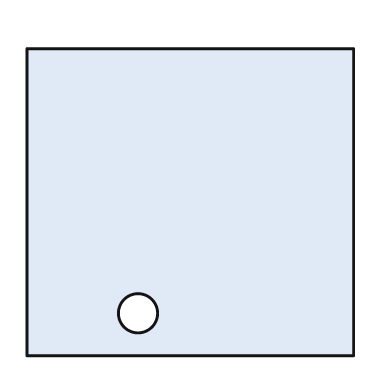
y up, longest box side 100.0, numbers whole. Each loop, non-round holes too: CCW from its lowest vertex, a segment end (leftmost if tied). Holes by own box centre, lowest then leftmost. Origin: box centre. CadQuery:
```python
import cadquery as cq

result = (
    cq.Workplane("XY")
    .moveTo(-50.0, -47.0)
    .lineTo(50.0, -47.0)
    .lineTo(50.0, 47.0)
    .lineTo(-50.0, 47.0)
    .close()
    .moveTo(-16.0, -34.0)
    .circle(6.0)
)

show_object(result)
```